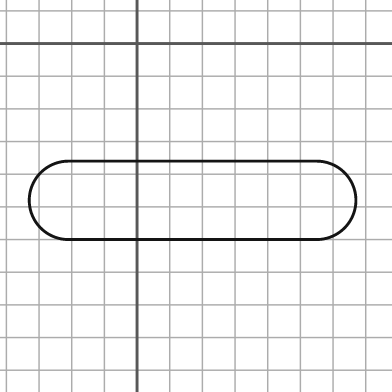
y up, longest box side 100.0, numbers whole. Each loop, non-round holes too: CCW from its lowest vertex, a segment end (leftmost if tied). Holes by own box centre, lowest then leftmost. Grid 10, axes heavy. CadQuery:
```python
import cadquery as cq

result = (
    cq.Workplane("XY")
    .moveTo(-21.0, -60.0)
    .lineTo(55.0, -60.0)
    .threePointArc((67.0, -48.0), (55.0, -36.0))
    .lineTo(-21.0, -36.0)
    .threePointArc((-33.0, -48.0), (-21.0, -60.0))
    .close()
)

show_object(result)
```